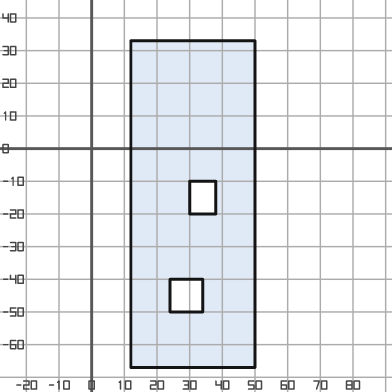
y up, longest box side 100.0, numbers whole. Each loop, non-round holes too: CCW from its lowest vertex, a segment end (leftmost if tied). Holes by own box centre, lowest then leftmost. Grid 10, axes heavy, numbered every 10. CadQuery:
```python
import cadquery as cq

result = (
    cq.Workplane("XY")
    .moveTo(12.0, -67.0)
    .lineTo(50.0, -67.0)
    .lineTo(50.0, 33.0)
    .lineTo(12.0, 33.0)
    .close()
    .moveTo(24.0, -50.0)
    .lineTo(34.0, -50.0)
    .lineTo(34.0, -40.0)
    .lineTo(24.0, -40.0)
    .close()
    .moveTo(30.0, -20.0)
    .lineTo(38.0, -20.0)
    .lineTo(38.0, -10.0)
    .lineTo(30.0, -10.0)
    .close()
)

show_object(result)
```